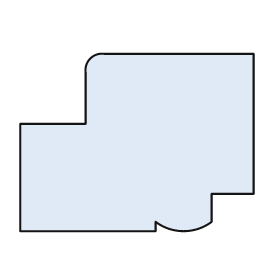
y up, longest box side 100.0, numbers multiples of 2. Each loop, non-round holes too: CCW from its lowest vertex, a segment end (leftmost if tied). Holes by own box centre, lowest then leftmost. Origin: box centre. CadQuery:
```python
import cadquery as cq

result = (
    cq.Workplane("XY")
    .moveTo(-50.0, -38.0)
    .lineTo(8.0, -38.0)
    .lineTo(8.0, -34.0)
    .threePointArc((20.0, -38.0), (32.0, -34.0))
    .lineTo(32.0, -22.0)
    .lineTo(50.0, -22.0)
    .lineTo(50.0, 38.0)
    .lineTo(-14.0, 38.0)
    .threePointArc((-20.0, 36.0), (-22.0, 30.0))
    .lineTo(-22.0, 8.0)
    .lineTo(-50.0, 8.0)
    .close()
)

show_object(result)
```